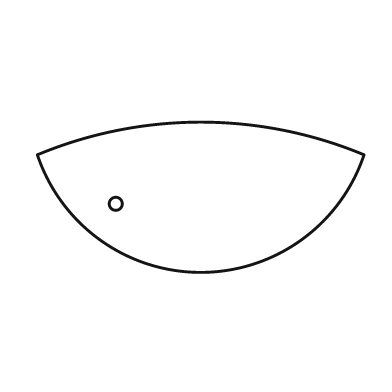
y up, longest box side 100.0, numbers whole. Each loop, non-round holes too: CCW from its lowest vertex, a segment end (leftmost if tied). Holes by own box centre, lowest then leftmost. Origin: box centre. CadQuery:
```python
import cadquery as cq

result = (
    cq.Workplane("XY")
    .moveTo(-50.0, 13.0)
    .threePointArc((0.0, -23.0), (50.0, 13.0))
    .threePointArc((0.0, 23.0), (-50.0, 13.0))
    .close()
    .moveTo(-26.0, -2.0)
    .circle(2.0)
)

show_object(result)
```